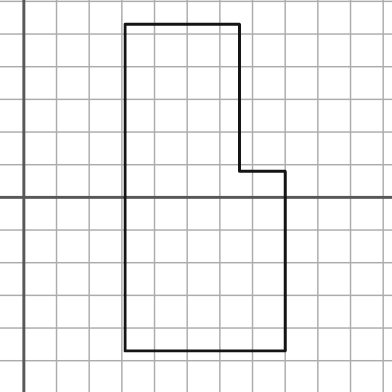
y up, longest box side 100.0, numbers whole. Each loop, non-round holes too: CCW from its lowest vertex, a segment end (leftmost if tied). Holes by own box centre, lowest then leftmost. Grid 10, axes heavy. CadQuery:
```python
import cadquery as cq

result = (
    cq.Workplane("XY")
    .moveTo(31.0, -47.0)
    .lineTo(80.0, -47.0)
    .lineTo(80.0, 8.0)
    .lineTo(66.0, 8.0)
    .lineTo(66.0, 53.0)
    .lineTo(31.0, 53.0)
    .close()
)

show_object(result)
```